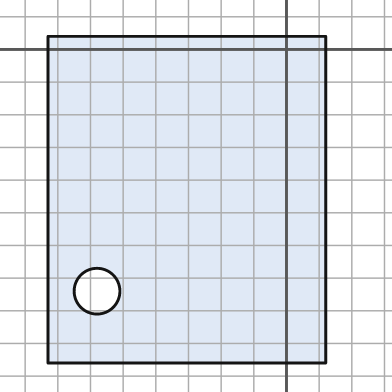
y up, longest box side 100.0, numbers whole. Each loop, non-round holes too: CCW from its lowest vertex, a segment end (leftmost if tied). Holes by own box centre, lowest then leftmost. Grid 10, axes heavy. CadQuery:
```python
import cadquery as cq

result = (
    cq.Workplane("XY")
    .moveTo(-73.0, -96.0)
    .lineTo(12.0, -96.0)
    .lineTo(12.0, 4.0)
    .lineTo(-73.0, 4.0)
    .close()
    .moveTo(-58.0, -74.0)
    .circle(7.0)
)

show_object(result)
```